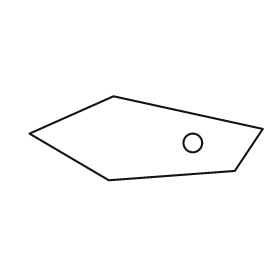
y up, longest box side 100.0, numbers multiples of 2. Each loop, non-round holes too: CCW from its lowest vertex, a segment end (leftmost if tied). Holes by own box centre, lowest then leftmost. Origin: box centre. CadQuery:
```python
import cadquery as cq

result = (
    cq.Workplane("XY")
    .moveTo(-16.0, -18.0)
    .lineTo(38.0, -14.0)
    .lineTo(50.0, 4.0)
    .lineTo(-14.0, 18.0)
    .lineTo(-50.0, 2.0)
    .close()
    .moveTo(20.0, -2.0)
    .circle(4.0)
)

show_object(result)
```